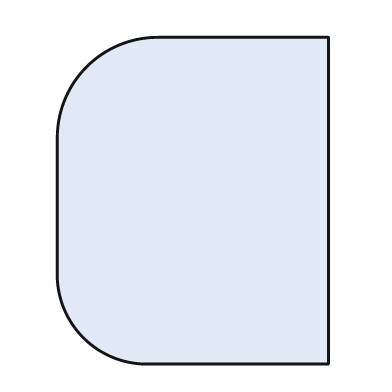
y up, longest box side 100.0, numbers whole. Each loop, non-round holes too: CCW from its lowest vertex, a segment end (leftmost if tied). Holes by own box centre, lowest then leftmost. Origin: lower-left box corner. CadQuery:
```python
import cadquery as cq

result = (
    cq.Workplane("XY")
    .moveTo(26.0, 0.0)
    .lineTo(83.0, 0.0)
    .lineTo(83.0, 100.0)
    .lineTo(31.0, 100.0)
    .threePointArc((9.0, 91.0), (0.0, 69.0))
    .lineTo(0.0, 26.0)
    .threePointArc((8.0, 8.0), (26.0, 0.0))
    .close()
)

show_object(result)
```